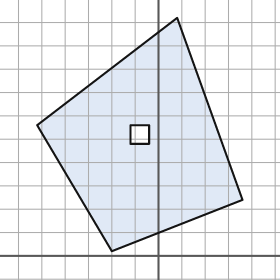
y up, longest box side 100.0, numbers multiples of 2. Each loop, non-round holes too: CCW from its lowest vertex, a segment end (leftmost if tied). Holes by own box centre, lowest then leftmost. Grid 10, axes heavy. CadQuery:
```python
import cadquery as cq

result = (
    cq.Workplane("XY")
    .moveTo(-20.0, 2.0)
    .lineTo(36.0, 24.0)
    .lineTo(8.0, 102.0)
    .lineTo(-52.0, 56.0)
    .close()
    .moveTo(-12.0, 48.0)
    .lineTo(-4.0, 48.0)
    .lineTo(-4.0, 56.0)
    .lineTo(-12.0, 56.0)
    .close()
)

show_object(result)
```